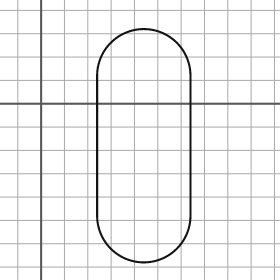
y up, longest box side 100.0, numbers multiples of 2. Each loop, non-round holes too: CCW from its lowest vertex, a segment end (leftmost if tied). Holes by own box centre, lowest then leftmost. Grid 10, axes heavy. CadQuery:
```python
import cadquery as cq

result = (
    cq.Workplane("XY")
    .moveTo(24.0, -48.0)
    .threePointArc((44.0, -68.0), (64.0, -48.0))
    .lineTo(64.0, 12.0)
    .threePointArc((44.0, 32.0), (24.0, 12.0))
    .close()
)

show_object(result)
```